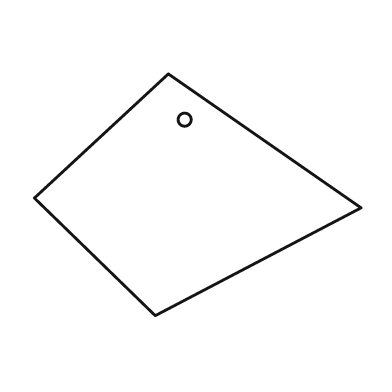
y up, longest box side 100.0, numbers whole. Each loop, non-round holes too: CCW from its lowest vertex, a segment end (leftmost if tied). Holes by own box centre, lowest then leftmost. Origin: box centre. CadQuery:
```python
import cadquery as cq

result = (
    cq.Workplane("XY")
    .moveTo(-13.0, -37.0)
    .lineTo(50.0, -4.0)
    .lineTo(-9.0, 37.0)
    .lineTo(-50.0, -1.0)
    .close()
    .moveTo(-4.0, 23.0)
    .circle(2.0)
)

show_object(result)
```